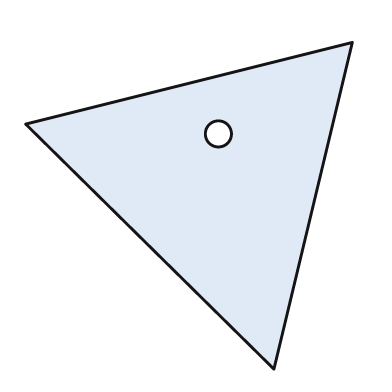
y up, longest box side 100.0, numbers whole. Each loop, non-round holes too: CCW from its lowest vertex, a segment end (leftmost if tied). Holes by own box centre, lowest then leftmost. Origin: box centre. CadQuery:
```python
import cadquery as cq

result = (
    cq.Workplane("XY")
    .moveTo(26.0, -50.0)
    .lineTo(50.0, 50.0)
    .lineTo(-50.0, 25.0)
    .close()
    .moveTo(9.0, 22.0)
    .circle(4.0)
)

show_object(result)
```